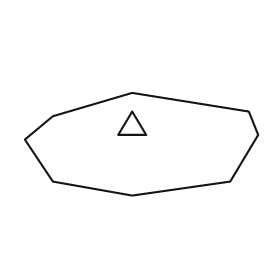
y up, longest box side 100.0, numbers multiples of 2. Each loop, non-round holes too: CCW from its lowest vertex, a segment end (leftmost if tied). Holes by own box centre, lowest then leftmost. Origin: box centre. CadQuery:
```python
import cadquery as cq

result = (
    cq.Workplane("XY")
    .moveTo(-4.0, -22.0)
    .lineTo(38.0, -16.0)
    .lineTo(50.0, 4.0)
    .lineTo(46.0, 14.0)
    .lineTo(-4.0, 22.0)
    .lineTo(-38.0, 12.0)
    .lineTo(-50.0, 2.0)
    .lineTo(-38.0, -16.0)
    .close()
    .moveTo(-10.0, 4.0)
    .lineTo(2.0, 4.0)
    .lineTo(-4.0, 14.0)
    .close()
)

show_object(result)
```